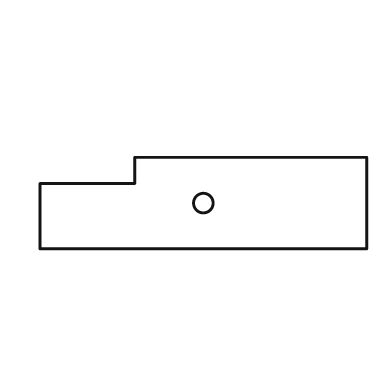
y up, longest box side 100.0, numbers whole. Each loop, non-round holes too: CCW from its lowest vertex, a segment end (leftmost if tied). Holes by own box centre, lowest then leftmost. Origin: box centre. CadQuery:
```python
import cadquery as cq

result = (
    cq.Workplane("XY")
    .moveTo(-50.0, -14.0)
    .lineTo(50.0, -14.0)
    .lineTo(50.0, 14.0)
    .lineTo(-21.0, 14.0)
    .lineTo(-21.0, 6.0)
    .lineTo(-50.0, 6.0)
    .close()
    .moveTo(0.0, 0.0)
    .circle(3.0)
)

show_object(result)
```